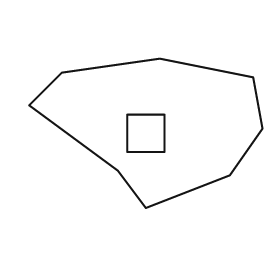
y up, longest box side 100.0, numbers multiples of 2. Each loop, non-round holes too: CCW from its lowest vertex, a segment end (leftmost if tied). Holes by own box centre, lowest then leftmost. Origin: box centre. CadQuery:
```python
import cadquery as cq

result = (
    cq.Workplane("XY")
    .moveTo(0.0, -32.0)
    .lineTo(36.0, -18.0)
    .lineTo(50.0, 2.0)
    .lineTo(46.0, 24.0)
    .lineTo(6.0, 32.0)
    .lineTo(-36.0, 26.0)
    .lineTo(-50.0, 12.0)
    .lineTo(-12.0, -16.0)
    .close()
    .moveTo(-8.0, -8.0)
    .lineTo(8.0, -8.0)
    .lineTo(8.0, 8.0)
    .lineTo(-8.0, 8.0)
    .close()
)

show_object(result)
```